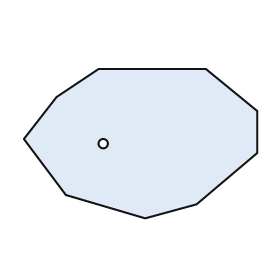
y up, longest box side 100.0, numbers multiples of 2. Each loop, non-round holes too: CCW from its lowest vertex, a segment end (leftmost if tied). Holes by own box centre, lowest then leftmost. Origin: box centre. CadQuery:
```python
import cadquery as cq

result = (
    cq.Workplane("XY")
    .moveTo(2.0, -32.0)
    .lineTo(24.0, -26.0)
    .lineTo(50.0, -4.0)
    .lineTo(50.0, 14.0)
    .lineTo(28.0, 32.0)
    .lineTo(-18.0, 32.0)
    .lineTo(-36.0, 20.0)
    .lineTo(-50.0, 2.0)
    .lineTo(-32.0, -22.0)
    .close()
    .moveTo(-16.0, 0.0)
    .circle(2.0)
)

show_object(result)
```